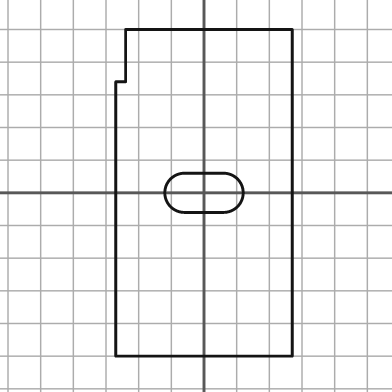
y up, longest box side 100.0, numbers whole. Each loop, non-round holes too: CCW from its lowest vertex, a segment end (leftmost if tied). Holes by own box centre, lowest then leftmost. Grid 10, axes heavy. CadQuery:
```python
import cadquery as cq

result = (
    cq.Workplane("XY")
    .moveTo(-27.0, -50.0)
    .lineTo(27.0, -50.0)
    .lineTo(27.0, 50.0)
    .lineTo(-24.0, 50.0)
    .lineTo(-24.0, 34.0)
    .lineTo(-27.0, 34.0)
    .close()
    .moveTo(-6.0, -6.0)
    .lineTo(6.0, -6.0)
    .threePointArc((12.0, 0.0), (6.0, 6.0))
    .lineTo(-6.0, 6.0)
    .threePointArc((-12.0, 0.0), (-6.0, -6.0))
    .close()
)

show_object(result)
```